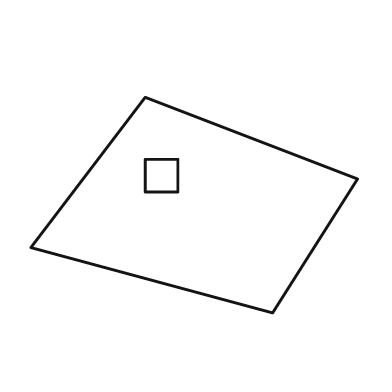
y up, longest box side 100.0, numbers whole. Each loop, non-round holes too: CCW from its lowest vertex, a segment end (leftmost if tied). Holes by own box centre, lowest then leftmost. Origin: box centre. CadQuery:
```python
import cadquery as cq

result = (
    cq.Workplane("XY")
    .moveTo(24.0, -33.0)
    .lineTo(50.0, 8.0)
    .lineTo(-15.0, 33.0)
    .lineTo(-50.0, -13.0)
    .close()
    .moveTo(-15.0, 4.0)
    .lineTo(-5.0, 4.0)
    .lineTo(-5.0, 14.0)
    .lineTo(-15.0, 14.0)
    .close()
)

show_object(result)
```